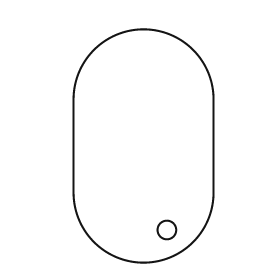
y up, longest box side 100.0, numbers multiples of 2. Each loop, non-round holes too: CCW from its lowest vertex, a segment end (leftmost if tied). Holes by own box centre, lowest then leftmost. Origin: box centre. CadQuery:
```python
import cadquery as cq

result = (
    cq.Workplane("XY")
    .moveTo(-30.0, -20.0)
    .threePointArc((0.0, -50.0), (30.0, -20.0))
    .lineTo(30.0, 20.0)
    .threePointArc((0.0, 50.0), (-30.0, 20.0))
    .close()
    .moveTo(10.0, -36.0)
    .circle(4.0)
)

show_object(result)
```